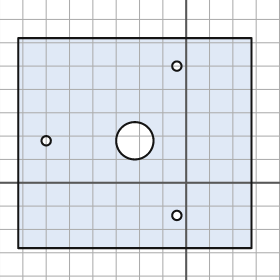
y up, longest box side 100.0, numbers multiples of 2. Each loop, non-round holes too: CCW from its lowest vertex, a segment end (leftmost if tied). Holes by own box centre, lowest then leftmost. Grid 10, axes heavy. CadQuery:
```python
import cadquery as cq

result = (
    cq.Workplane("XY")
    .moveTo(-72.0, -28.0)
    .lineTo(28.0, -28.0)
    .lineTo(28.0, 62.0)
    .lineTo(-72.0, 62.0)
    .close()
    .moveTo(-4.0, -14.0)
    .circle(2.0)
    .moveTo(-60.0, 18.0)
    .circle(2.0)
    .moveTo(-22.0, 18.0)
    .circle(8.0)
    .moveTo(-4.0, 50.0)
    .circle(2.0)
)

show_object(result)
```